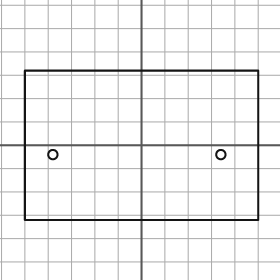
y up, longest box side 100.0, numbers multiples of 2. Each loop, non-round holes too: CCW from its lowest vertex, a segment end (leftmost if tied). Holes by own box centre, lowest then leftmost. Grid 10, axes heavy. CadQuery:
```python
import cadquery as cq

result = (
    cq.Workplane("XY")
    .moveTo(-50.0, -32.0)
    .lineTo(50.0, -32.0)
    .lineTo(50.0, 32.0)
    .lineTo(-50.0, 32.0)
    .close()
    .moveTo(-38.0, -4.0)
    .circle(2.0)
    .moveTo(34.0, -4.0)
    .circle(2.0)
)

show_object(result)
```